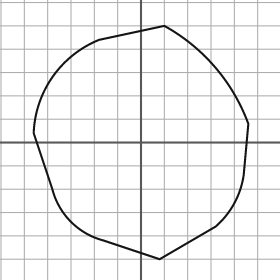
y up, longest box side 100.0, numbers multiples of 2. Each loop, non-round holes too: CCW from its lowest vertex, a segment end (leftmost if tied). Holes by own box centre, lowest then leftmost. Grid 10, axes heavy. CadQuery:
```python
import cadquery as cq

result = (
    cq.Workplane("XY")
    .moveTo(8.0, -50.0)
    .lineTo(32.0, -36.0)
    .threePointArc((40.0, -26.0), (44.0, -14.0))
    .lineTo(46.0, 8.0)
    .threePointArc((32.0, 32.0), (10.0, 50.0))
    .lineTo(-18.0, 44.0)
    .threePointArc((-38.0, 28.0), (-46.0, 4.0))
    .lineTo(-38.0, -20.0)
    .threePointArc((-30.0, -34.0), (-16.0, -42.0))
    .close()
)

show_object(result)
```